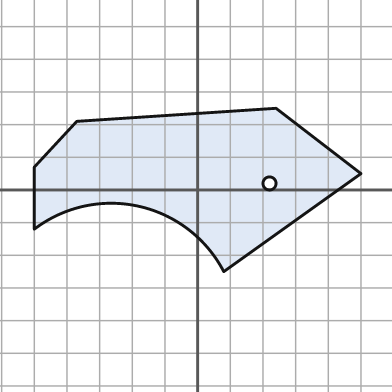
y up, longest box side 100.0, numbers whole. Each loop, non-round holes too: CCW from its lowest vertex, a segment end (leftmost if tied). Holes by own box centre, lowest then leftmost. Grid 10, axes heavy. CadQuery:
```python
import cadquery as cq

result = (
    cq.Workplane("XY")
    .moveTo(8.0, -25.0)
    .lineTo(50.0, 5.0)
    .lineTo(24.0, 25.0)
    .lineTo(-37.0, 21.0)
    .lineTo(-50.0, 7.0)
    .lineTo(-50.0, -12.0)
    .threePointArc((-18.0, -5.0), (8.0, -25.0))
    .close()
    .moveTo(22.0, 2.0)
    .circle(2.0)
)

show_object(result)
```